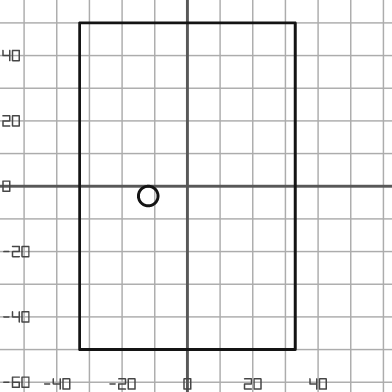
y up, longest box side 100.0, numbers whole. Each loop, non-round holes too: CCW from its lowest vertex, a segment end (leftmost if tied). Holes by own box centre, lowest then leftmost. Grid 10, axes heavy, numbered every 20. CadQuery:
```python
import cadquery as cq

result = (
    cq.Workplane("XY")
    .moveTo(-33.0, -50.0)
    .lineTo(33.0, -50.0)
    .lineTo(33.0, 50.0)
    .lineTo(-33.0, 50.0)
    .close()
    .moveTo(-12.0, -3.0)
    .circle(3.0)
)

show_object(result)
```